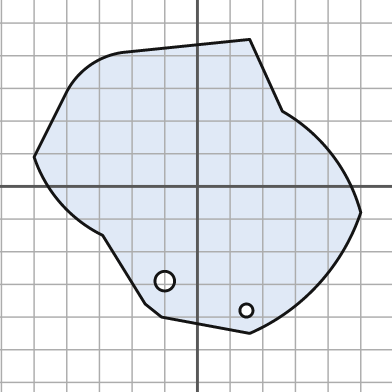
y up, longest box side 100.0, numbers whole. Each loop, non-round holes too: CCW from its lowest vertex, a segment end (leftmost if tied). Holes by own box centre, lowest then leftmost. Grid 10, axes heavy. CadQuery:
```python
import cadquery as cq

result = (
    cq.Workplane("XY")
    .moveTo(16.0, -45.0)
    .threePointArc((37.0, -30.0), (50.0, -8.0))
    .threePointArc((41.0, 10.0), (26.0, 23.0))
    .lineTo(16.0, 45.0)
    .lineTo(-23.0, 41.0)
    .threePointArc((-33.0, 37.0), (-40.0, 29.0))
    .lineTo(-50.0, 9.0)
    .threePointArc((-42.0, -5.0), (-29.0, -15.0))
    .lineTo(-16.0, -36.0)
    .lineTo(-11.0, -40.0)
    .close()
    .moveTo(15.0, -38.0)
    .circle(2.0)
    .moveTo(-10.0, -29.0)
    .circle(3.0)
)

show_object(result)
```